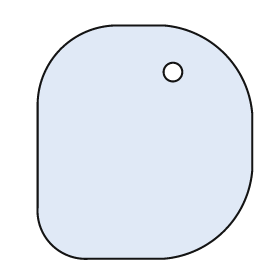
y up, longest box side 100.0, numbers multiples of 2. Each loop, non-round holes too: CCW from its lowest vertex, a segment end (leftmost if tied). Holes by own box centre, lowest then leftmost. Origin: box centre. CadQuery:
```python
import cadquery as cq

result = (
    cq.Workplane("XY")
    .moveTo(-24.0, -50.0)
    .lineTo(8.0, -50.0)
    .threePointArc((34.0, -38.0), (46.0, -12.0))
    .lineTo(46.0, 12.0)
    .threePointArc((34.0, 38.0), (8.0, 50.0))
    .lineTo(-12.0, 50.0)
    .threePointArc((-36.0, 40.0), (-46.0, 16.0))
    .lineTo(-46.0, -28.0)
    .threePointArc((-40.0, -44.0), (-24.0, -50.0))
    .close()
    .moveTo(12.0, 30.0)
    .circle(4.0)
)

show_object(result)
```